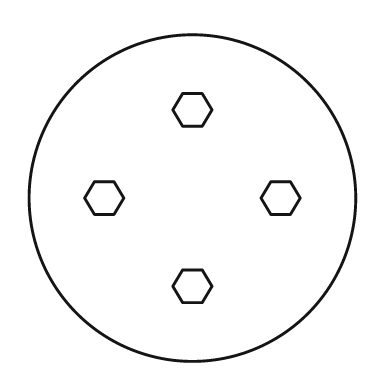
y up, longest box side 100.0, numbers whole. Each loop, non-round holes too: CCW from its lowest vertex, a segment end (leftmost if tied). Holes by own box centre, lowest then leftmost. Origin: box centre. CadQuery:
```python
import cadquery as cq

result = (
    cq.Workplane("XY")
    .moveTo(0.0, 0.0)
    .circle(50.0)
    .moveTo(-3.0, -32.0)
    .lineTo(3.0, -32.0)
    .lineTo(6.0, -27.0)
    .lineTo(3.0, -22.0)
    .lineTo(-3.0, -22.0)
    .lineTo(-6.0, -27.0)
    .close()
    .moveTo(-30.0, -5.0)
    .lineTo(-24.0, -5.0)
    .lineTo(-21.0, 0.0)
    .lineTo(-24.0, 5.0)
    .lineTo(-30.0, 5.0)
    .lineTo(-33.0, 0.0)
    .close()
    .moveTo(24.0, -5.0)
    .lineTo(30.0, -5.0)
    .lineTo(33.0, 0.0)
    .lineTo(30.0, 5.0)
    .lineTo(24.0, 5.0)
    .lineTo(21.0, 0.0)
    .close()
    .moveTo(-3.0, 22.0)
    .lineTo(3.0, 22.0)
    .lineTo(6.0, 27.0)
    .lineTo(3.0, 32.0)
    .lineTo(-3.0, 32.0)
    .lineTo(-6.0, 27.0)
    .close()
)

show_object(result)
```